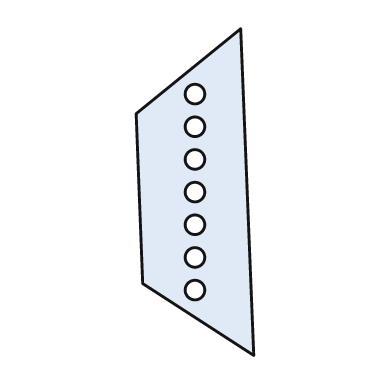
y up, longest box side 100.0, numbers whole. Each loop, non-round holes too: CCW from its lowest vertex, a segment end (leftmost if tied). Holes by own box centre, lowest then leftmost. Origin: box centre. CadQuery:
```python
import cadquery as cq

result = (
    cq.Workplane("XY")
    .moveTo(18.0, -50.0)
    .lineTo(14.0, 50.0)
    .lineTo(-18.0, 24.0)
    .lineTo(-16.0, -28.0)
    .close()
    .moveTo(0.0, -30.0)
    .circle(3.0)
    .moveTo(0.0, -20.0)
    .circle(3.0)
    .moveTo(0.0, -10.0)
    .circle(3.0)
    .moveTo(0.0, 0.0)
    .circle(3.0)
    .moveTo(0.0, 10.0)
    .circle(3.0)
    .moveTo(0.0, 20.0)
    .circle(3.0)
    .moveTo(0.0, 30.0)
    .circle(3.0)
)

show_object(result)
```